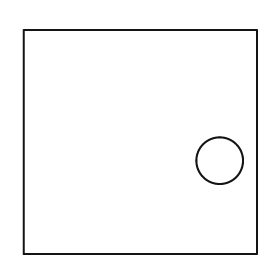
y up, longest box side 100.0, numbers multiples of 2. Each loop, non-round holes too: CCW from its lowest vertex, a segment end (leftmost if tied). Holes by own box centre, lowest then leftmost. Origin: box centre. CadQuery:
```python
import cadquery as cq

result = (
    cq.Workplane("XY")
    .moveTo(-50.0, -48.0)
    .lineTo(50.0, -48.0)
    .lineTo(50.0, 48.0)
    .lineTo(-50.0, 48.0)
    .close()
    .moveTo(34.0, -8.0)
    .circle(10.0)
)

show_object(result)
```